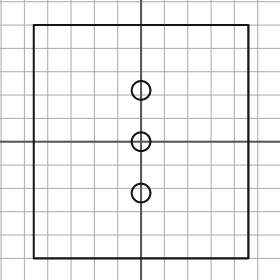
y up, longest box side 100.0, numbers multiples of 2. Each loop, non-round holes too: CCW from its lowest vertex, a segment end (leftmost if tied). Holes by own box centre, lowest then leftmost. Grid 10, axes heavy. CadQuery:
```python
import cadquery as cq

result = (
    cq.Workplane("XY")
    .moveTo(-46.0, -50.0)
    .lineTo(46.0, -50.0)
    .lineTo(46.0, 50.0)
    .lineTo(-46.0, 50.0)
    .close()
    .moveTo(0.0, -22.0)
    .circle(4.0)
    .moveTo(0.0, 0.0)
    .circle(4.0)
    .moveTo(0.0, 22.0)
    .circle(4.0)
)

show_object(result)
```